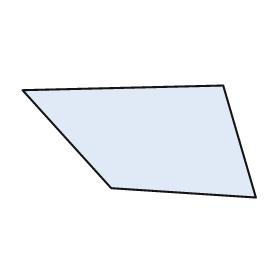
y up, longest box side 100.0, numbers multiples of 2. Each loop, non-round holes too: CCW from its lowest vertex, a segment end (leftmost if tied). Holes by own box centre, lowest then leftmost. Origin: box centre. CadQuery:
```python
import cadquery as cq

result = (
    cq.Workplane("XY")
    .moveTo(50.0, -24.0)
    .lineTo(36.0, 24.0)
    .lineTo(-50.0, 22.0)
    .lineTo(-12.0, -20.0)
    .close()
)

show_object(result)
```